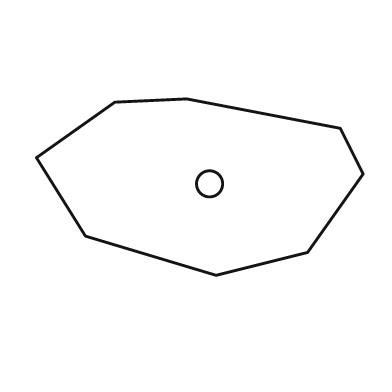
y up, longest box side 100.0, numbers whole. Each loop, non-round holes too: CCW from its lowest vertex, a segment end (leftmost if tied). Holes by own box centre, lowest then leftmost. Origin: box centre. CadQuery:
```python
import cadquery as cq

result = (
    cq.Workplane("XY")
    .moveTo(5.0, -27.0)
    .lineTo(33.0, -20.0)
    .lineTo(50.0, 4.0)
    .lineTo(43.0, 18.0)
    .lineTo(-4.0, 27.0)
    .lineTo(-26.0, 26.0)
    .lineTo(-50.0, 9.0)
    .lineTo(-35.0, -15.0)
    .close()
    .moveTo(3.0, 1.0)
    .circle(4.0)
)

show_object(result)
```